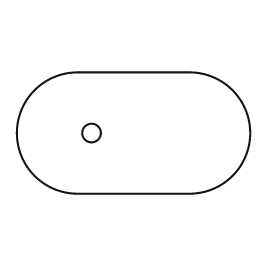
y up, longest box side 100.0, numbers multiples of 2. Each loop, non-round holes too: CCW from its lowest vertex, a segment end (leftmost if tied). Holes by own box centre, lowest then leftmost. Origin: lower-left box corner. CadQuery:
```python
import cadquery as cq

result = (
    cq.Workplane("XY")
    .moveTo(26.0, 0.0)
    .lineTo(74.0, 0.0)
    .threePointArc((100.0, 26.0), (74.0, 52.0))
    .lineTo(26.0, 52.0)
    .threePointArc((0.0, 26.0), (26.0, 0.0))
    .close()
    .moveTo(32.0, 26.0)
    .circle(4.0)
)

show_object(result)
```